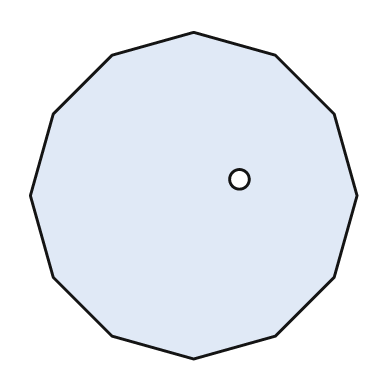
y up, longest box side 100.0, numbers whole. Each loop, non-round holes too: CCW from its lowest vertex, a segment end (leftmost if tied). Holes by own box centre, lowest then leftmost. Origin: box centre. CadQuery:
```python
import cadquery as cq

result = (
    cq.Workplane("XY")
    .moveTo(0.0, -50.0)
    .lineTo(25.0, -43.0)
    .lineTo(43.0, -25.0)
    .lineTo(50.0, 0.0)
    .lineTo(43.0, 25.0)
    .lineTo(25.0, 43.0)
    .lineTo(0.0, 50.0)
    .lineTo(-25.0, 43.0)
    .lineTo(-43.0, 25.0)
    .lineTo(-50.0, 0.0)
    .lineTo(-43.0, -25.0)
    .lineTo(-25.0, -43.0)
    .close()
    .moveTo(14.0, 5.0)
    .circle(3.0)
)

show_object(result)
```